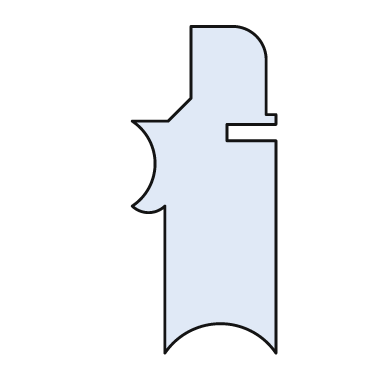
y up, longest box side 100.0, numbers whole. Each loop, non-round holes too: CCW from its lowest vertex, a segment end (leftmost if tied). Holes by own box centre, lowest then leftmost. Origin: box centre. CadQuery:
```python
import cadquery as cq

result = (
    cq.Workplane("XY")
    .moveTo(-12.0, -50.0)
    .threePointArc((5.0, -41.0), (22.0, -50.0))
    .lineTo(22.0, 15.0)
    .lineTo(7.0, 15.0)
    .lineTo(7.0, 20.0)
    .lineTo(22.0, 20.0)
    .lineTo(22.0, 23.0)
    .lineTo(19.0, 23.0)
    .lineTo(19.0, 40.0)
    .threePointArc((16.0, 47.0), (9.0, 50.0))
    .lineTo(-4.0, 50.0)
    .lineTo(-4.0, 28.0)
    .lineTo(-11.0, 21.0)
    .lineTo(-22.0, 21.0)
    .threePointArc((-15.0, 8.0), (-22.0, -5.0))
    .threePointArc((-17.0, -7.0), (-12.0, -5.0))
    .close()
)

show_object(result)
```